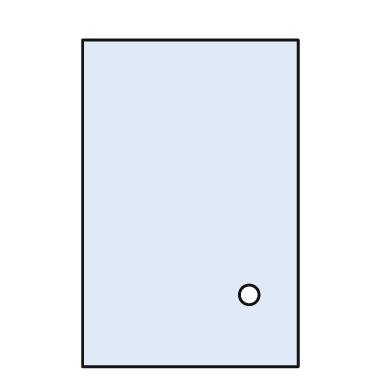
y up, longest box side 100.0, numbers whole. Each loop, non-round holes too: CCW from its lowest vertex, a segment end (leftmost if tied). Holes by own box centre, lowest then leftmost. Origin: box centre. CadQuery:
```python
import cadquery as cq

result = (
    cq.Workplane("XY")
    .moveTo(-33.0, -50.0)
    .lineTo(33.0, -50.0)
    .lineTo(33.0, 50.0)
    .lineTo(-33.0, 50.0)
    .close()
    .moveTo(18.0, -28.0)
    .circle(3.0)
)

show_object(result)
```